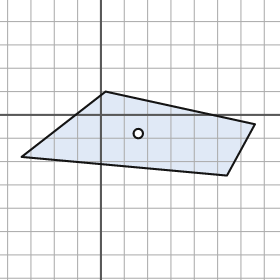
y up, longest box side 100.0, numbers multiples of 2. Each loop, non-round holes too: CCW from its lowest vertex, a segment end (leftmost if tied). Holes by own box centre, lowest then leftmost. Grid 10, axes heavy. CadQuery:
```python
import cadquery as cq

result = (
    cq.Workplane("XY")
    .moveTo(54.0, -26.0)
    .lineTo(66.0, -4.0)
    .lineTo(2.0, 10.0)
    .lineTo(-34.0, -18.0)
    .close()
    .moveTo(16.0, -8.0)
    .circle(2.0)
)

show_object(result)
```